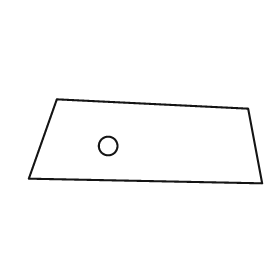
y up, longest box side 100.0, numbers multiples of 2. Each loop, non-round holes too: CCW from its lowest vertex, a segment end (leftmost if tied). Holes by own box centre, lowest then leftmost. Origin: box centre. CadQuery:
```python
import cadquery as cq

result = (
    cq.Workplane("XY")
    .moveTo(50.0, -18.0)
    .lineTo(44.0, 14.0)
    .lineTo(-38.0, 18.0)
    .lineTo(-50.0, -16.0)
    .close()
    .moveTo(-16.0, -2.0)
    .circle(4.0)
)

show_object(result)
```